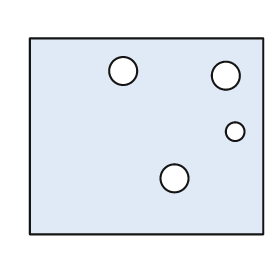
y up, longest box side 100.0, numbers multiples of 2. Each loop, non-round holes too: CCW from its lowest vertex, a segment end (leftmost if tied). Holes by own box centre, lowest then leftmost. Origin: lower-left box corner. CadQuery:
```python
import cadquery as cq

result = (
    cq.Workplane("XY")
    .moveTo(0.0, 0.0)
    .lineTo(100.0, 0.0)
    .lineTo(100.0, 84.0)
    .lineTo(0.0, 84.0)
    .close()
    .moveTo(62.0, 24.0)
    .circle(6.0)
    .moveTo(88.0, 44.0)
    .circle(4.0)
    .moveTo(84.0, 68.0)
    .circle(6.0)
    .moveTo(40.0, 70.0)
    .circle(6.0)
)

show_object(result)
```